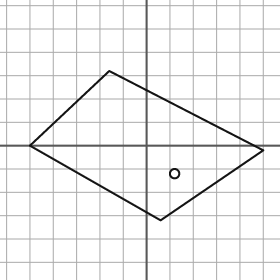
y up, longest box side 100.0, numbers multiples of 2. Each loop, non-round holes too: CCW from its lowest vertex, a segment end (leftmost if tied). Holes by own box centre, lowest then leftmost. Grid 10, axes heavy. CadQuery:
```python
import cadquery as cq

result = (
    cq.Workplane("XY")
    .moveTo(6.0, -32.0)
    .lineTo(50.0, -2.0)
    .lineTo(-16.0, 32.0)
    .lineTo(-50.0, 0.0)
    .close()
    .moveTo(12.0, -12.0)
    .circle(2.0)
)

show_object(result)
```